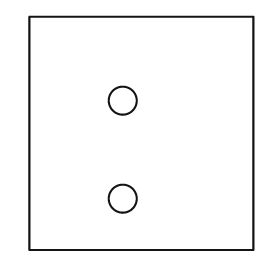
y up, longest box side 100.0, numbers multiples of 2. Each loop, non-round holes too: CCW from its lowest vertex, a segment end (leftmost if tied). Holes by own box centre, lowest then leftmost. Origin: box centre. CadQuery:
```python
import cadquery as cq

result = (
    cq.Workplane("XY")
    .moveTo(-48.0, -50.0)
    .lineTo(48.0, -50.0)
    .lineTo(48.0, 50.0)
    .lineTo(-48.0, 50.0)
    .close()
    .moveTo(-8.0, -28.0)
    .circle(6.0)
    .moveTo(-8.0, 14.0)
    .circle(6.0)
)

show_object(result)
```